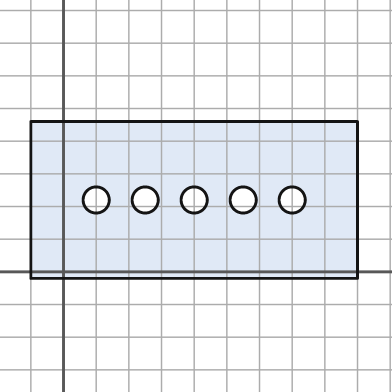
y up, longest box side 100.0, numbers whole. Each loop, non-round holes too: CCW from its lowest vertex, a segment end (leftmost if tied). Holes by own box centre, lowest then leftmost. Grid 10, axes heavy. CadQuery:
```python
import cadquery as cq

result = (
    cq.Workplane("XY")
    .moveTo(-10.0, -2.0)
    .lineTo(90.0, -2.0)
    .lineTo(90.0, 46.0)
    .lineTo(-10.0, 46.0)
    .close()
    .moveTo(10.0, 22.0)
    .circle(4.0)
    .moveTo(25.0, 22.0)
    .circle(4.0)
    .moveTo(40.0, 22.0)
    .circle(4.0)
    .moveTo(55.0, 22.0)
    .circle(4.0)
    .moveTo(70.0, 22.0)
    .circle(4.0)
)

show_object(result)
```